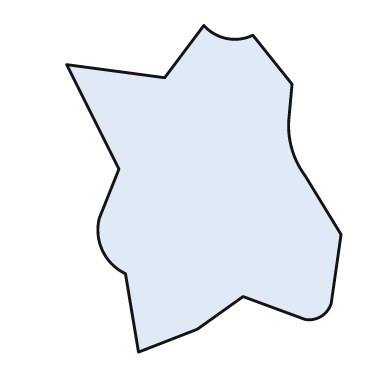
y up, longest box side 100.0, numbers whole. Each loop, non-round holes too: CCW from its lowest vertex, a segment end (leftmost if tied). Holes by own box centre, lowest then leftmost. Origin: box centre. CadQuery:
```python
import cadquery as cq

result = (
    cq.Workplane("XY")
    .moveTo(-20.0, -50.0)
    .lineTo(-2.0, -43.0)
    .lineTo(12.0, -33.0)
    .lineTo(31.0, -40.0)
    .threePointArc((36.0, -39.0), (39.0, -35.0))
    .lineTo(42.0, -14.0)
    .lineTo(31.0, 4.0)
    .threePointArc((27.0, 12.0), (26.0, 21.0))
    .lineTo(27.0, 32.0)
    .lineTo(15.0, 47.0)
    .threePointArc((7.0, 46.0), (0.0, 50.0))
    .lineTo(-12.0, 34.0)
    .lineTo(-42.0, 38.0)
    .lineTo(-26.0, 6.0)
    .lineTo(-32.0, -9.0)
    .threePointArc((-31.0, -19.0), (-24.0, -26.0))
    .close()
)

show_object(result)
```